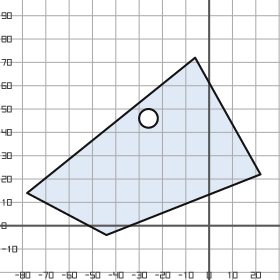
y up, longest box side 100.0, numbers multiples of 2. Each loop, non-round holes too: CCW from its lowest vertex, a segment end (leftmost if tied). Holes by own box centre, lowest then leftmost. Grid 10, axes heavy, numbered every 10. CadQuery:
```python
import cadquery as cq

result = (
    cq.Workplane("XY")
    .moveTo(-44.0, -4.0)
    .lineTo(22.0, 22.0)
    .lineTo(-6.0, 72.0)
    .lineTo(-78.0, 14.0)
    .close()
    .moveTo(-26.0, 46.0)
    .circle(4.0)
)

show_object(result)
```